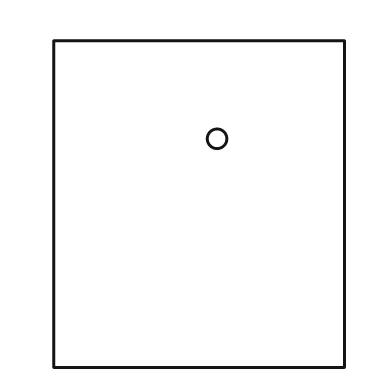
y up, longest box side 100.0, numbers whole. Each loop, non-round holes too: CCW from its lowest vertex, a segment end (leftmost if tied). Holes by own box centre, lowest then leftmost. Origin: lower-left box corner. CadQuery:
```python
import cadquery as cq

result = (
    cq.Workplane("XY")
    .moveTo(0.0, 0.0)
    .lineTo(89.0, 0.0)
    .lineTo(89.0, 100.0)
    .lineTo(0.0, 100.0)
    .close()
    .moveTo(50.0, 70.0)
    .circle(3.0)
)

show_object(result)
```